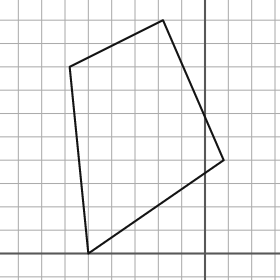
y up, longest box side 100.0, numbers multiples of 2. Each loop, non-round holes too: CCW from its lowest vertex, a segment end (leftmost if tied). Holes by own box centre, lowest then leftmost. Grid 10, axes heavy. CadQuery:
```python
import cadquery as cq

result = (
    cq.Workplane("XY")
    .moveTo(-50.0, 0.0)
    .lineTo(8.0, 40.0)
    .lineTo(-18.0, 100.0)
    .lineTo(-58.0, 80.0)
    .close()
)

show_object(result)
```